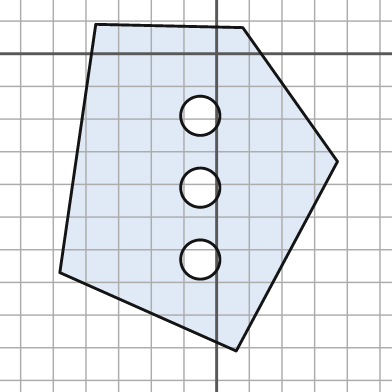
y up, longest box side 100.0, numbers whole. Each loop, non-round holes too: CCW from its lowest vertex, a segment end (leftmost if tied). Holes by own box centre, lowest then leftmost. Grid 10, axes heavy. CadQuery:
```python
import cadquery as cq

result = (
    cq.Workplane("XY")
    .moveTo(6.0, -91.0)
    .lineTo(37.0, -33.0)
    .lineTo(8.0, 8.0)
    .lineTo(-37.0, 9.0)
    .lineTo(-48.0, -67.0)
    .close()
    .moveTo(-5.0, -63.0)
    .circle(6.0)
    .moveTo(-5.0, -41.0)
    .circle(6.0)
    .moveTo(-5.0, -19.0)
    .circle(6.0)
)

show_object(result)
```